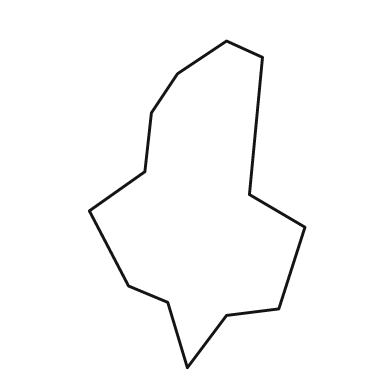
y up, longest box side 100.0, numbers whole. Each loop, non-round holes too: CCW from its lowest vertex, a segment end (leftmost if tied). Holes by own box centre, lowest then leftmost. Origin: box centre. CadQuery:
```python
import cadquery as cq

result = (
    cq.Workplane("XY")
    .moveTo(-3.0, -50.0)
    .lineTo(9.0, -34.0)
    .lineTo(25.0, -32.0)
    .lineTo(33.0, -7.0)
    .lineTo(16.0, 3.0)
    .lineTo(20.0, 45.0)
    .lineTo(9.0, 50.0)
    .lineTo(-6.0, 40.0)
    .lineTo(-14.0, 28.0)
    .lineTo(-16.0, 10.0)
    .lineTo(-33.0, -2.0)
    .lineTo(-21.0, -25.0)
    .lineTo(-9.0, -30.0)
    .close()
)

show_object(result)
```